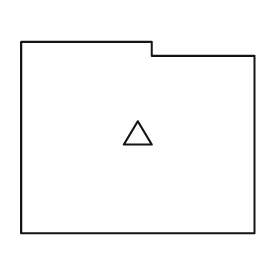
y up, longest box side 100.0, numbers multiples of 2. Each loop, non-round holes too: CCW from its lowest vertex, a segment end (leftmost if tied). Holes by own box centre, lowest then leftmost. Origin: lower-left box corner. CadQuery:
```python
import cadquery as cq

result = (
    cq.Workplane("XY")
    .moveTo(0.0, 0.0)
    .lineTo(100.0, 0.0)
    .lineTo(100.0, 76.0)
    .lineTo(56.0, 76.0)
    .lineTo(56.0, 82.0)
    .lineTo(0.0, 82.0)
    .close()
    .moveTo(44.0, 38.0)
    .lineTo(56.0, 38.0)
    .lineTo(50.0, 48.0)
    .close()
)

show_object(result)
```